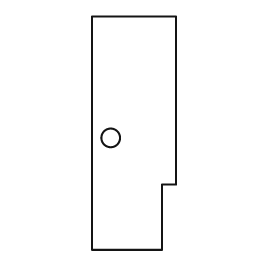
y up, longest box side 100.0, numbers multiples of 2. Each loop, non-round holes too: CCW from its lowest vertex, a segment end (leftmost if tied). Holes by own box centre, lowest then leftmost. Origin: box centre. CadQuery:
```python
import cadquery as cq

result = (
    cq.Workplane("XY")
    .moveTo(-18.0, -50.0)
    .lineTo(12.0, -50.0)
    .lineTo(12.0, -22.0)
    .lineTo(18.0, -22.0)
    .lineTo(18.0, 50.0)
    .lineTo(-18.0, 50.0)
    .close()
    .moveTo(-10.0, -2.0)
    .circle(4.0)
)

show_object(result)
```